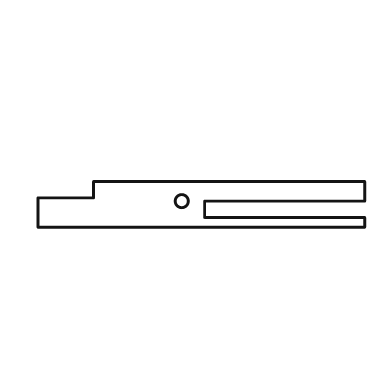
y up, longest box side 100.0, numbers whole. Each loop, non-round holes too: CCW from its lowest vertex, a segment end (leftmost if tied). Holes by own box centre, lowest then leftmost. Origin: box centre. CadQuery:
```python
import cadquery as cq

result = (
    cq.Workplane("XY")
    .moveTo(-50.0, -7.0)
    .lineTo(50.0, -7.0)
    .lineTo(50.0, -4.0)
    .lineTo(1.0, -4.0)
    .lineTo(1.0, 1.0)
    .lineTo(50.0, 1.0)
    .lineTo(50.0, 7.0)
    .lineTo(-33.0, 7.0)
    .lineTo(-33.0, 2.0)
    .lineTo(-50.0, 2.0)
    .close()
    .moveTo(-6.0, 1.0)
    .circle(2.0)
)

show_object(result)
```